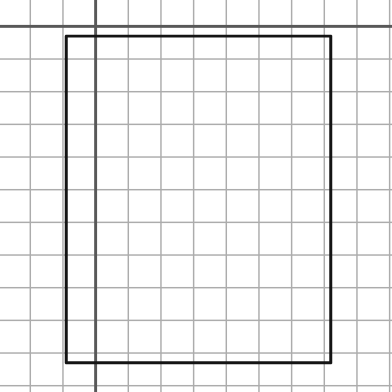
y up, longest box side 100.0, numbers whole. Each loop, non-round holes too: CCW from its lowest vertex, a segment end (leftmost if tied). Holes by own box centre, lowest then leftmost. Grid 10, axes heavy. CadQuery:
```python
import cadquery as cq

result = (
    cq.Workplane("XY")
    .moveTo(-9.0, -103.0)
    .lineTo(72.0, -103.0)
    .lineTo(72.0, -3.0)
    .lineTo(-9.0, -3.0)
    .close()
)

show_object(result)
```